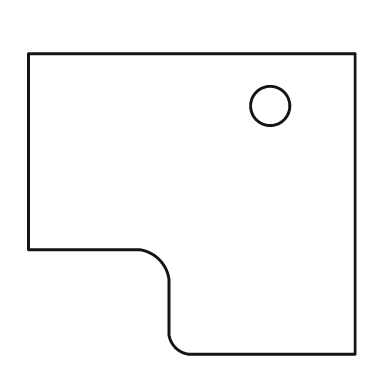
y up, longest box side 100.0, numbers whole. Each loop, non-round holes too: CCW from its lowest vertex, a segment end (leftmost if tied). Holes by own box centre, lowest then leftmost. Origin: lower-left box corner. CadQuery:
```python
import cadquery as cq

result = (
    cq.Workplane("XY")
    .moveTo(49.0, 0.0)
    .lineTo(100.0, 0.0)
    .lineTo(100.0, 92.0)
    .lineTo(0.0, 92.0)
    .lineTo(0.0, 32.0)
    .lineTo(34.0, 32.0)
    .threePointArc((40.0, 29.0), (43.0, 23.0))
    .lineTo(43.0, 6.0)
    .threePointArc((45.0, 2.0), (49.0, 0.0))
    .close()
    .moveTo(74.0, 76.0)
    .circle(6.0)
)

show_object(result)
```